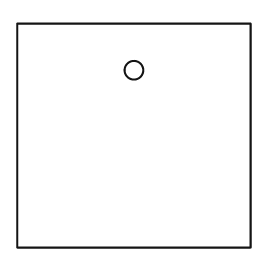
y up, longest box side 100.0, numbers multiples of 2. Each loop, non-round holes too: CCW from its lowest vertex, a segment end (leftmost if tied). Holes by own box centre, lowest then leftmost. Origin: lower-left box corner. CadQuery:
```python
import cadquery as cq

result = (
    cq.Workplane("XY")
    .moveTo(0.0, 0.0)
    .lineTo(100.0, 0.0)
    .lineTo(100.0, 96.0)
    .lineTo(0.0, 96.0)
    .close()
    .moveTo(50.0, 76.0)
    .circle(4.0)
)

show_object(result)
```